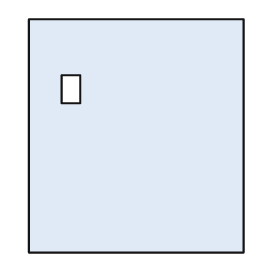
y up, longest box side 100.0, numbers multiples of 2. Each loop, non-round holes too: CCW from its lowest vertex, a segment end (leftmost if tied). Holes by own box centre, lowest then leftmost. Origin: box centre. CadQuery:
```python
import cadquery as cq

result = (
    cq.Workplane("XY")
    .moveTo(-46.0, -50.0)
    .lineTo(46.0, -50.0)
    .lineTo(46.0, 50.0)
    .lineTo(-46.0, 50.0)
    .close()
    .moveTo(-32.0, 14.0)
    .lineTo(-24.0, 14.0)
    .lineTo(-24.0, 26.0)
    .lineTo(-32.0, 26.0)
    .close()
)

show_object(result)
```